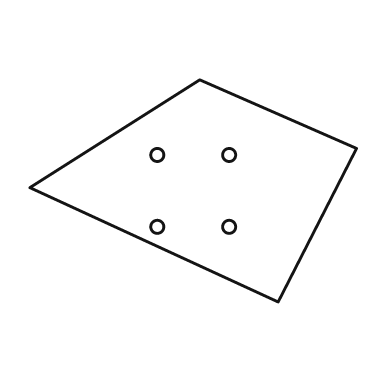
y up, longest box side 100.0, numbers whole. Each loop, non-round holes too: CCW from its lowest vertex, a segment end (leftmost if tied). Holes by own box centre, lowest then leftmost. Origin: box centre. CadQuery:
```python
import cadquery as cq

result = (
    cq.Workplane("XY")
    .moveTo(26.0, -34.0)
    .lineTo(50.0, 13.0)
    .lineTo(2.0, 34.0)
    .lineTo(-50.0, 1.0)
    .close()
    .moveTo(-11.0, -11.0)
    .circle(2.0)
    .moveTo(11.0, -11.0)
    .circle(2.0)
    .moveTo(-11.0, 11.0)
    .circle(2.0)
    .moveTo(11.0, 11.0)
    .circle(2.0)
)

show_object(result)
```